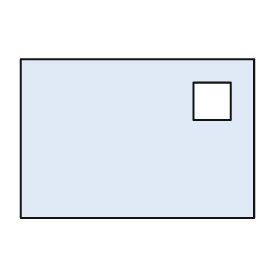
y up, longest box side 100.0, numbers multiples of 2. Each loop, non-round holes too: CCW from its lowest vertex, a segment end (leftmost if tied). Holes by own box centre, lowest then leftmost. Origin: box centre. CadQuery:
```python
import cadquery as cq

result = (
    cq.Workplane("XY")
    .moveTo(-50.0, -34.0)
    .lineTo(50.0, -34.0)
    .lineTo(50.0, 34.0)
    .lineTo(-50.0, 34.0)
    .close()
    .moveTo(24.0, 8.0)
    .lineTo(40.0, 8.0)
    .lineTo(40.0, 24.0)
    .lineTo(24.0, 24.0)
    .close()
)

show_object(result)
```